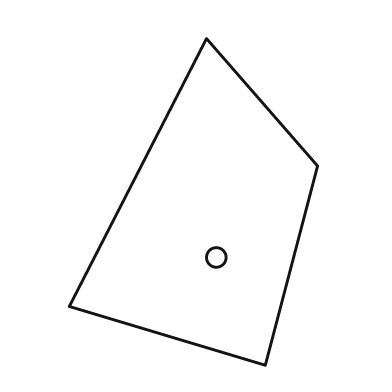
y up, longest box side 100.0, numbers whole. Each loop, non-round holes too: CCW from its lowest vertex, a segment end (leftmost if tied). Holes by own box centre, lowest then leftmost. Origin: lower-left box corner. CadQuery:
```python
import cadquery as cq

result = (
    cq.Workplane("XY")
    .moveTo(60.0, 0.0)
    .lineTo(76.0, 61.0)
    .lineTo(42.0, 100.0)
    .lineTo(0.0, 18.0)
    .close()
    .moveTo(45.0, 33.0)
    .circle(3.0)
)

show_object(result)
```